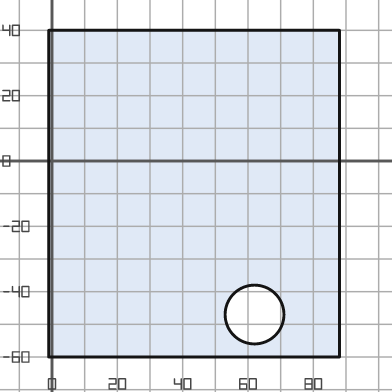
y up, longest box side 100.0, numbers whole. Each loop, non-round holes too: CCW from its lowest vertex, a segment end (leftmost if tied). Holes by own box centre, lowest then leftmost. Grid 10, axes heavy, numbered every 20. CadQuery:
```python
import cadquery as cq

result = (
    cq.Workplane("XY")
    .moveTo(-1.0, -60.0)
    .lineTo(88.0, -60.0)
    .lineTo(88.0, 40.0)
    .lineTo(-1.0, 40.0)
    .close()
    .moveTo(62.0, -47.0)
    .circle(9.0)
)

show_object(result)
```